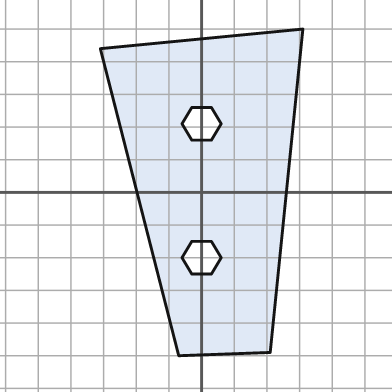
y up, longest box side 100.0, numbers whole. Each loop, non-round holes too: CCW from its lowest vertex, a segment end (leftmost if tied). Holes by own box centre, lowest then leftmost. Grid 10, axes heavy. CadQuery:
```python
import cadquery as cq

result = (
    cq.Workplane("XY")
    .moveTo(-7.0, -50.0)
    .lineTo(21.0, -49.0)
    .lineTo(31.0, 50.0)
    .lineTo(-31.0, 44.0)
    .close()
    .moveTo(-3.0, -25.0)
    .lineTo(3.0, -25.0)
    .lineTo(6.0, -20.0)
    .lineTo(3.0, -15.0)
    .lineTo(-3.0, -15.0)
    .lineTo(-6.0, -20.0)
    .close()
    .moveTo(-3.0, 16.0)
    .lineTo(3.0, 16.0)
    .lineTo(6.0, 21.0)
    .lineTo(3.0, 26.0)
    .lineTo(-3.0, 26.0)
    .lineTo(-6.0, 21.0)
    .close()
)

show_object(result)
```